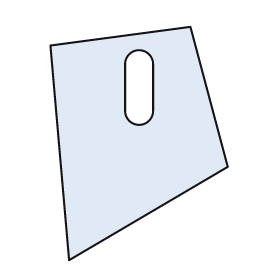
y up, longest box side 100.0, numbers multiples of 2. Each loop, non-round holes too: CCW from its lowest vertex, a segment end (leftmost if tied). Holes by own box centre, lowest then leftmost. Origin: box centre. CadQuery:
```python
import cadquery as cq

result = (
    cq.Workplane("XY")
    .moveTo(-30.0, -50.0)
    .lineTo(38.0, -10.0)
    .lineTo(22.0, 50.0)
    .lineTo(-38.0, 42.0)
    .close()
    .moveTo(-6.0, 14.0)
    .threePointArc((0.0, 8.0), (6.0, 14.0))
    .lineTo(6.0, 34.0)
    .threePointArc((0.0, 40.0), (-6.0, 34.0))
    .close()
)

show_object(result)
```